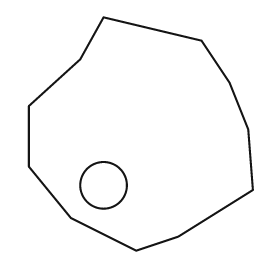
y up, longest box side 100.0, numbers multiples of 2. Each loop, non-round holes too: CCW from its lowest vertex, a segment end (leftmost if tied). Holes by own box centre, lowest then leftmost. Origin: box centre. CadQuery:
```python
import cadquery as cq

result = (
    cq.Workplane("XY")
    .moveTo(-2.0, -50.0)
    .lineTo(16.0, -44.0)
    .lineTo(48.0, -24.0)
    .lineTo(46.0, 2.0)
    .lineTo(38.0, 22.0)
    .lineTo(26.0, 40.0)
    .lineTo(-16.0, 50.0)
    .lineTo(-26.0, 32.0)
    .lineTo(-48.0, 12.0)
    .lineTo(-48.0, -14.0)
    .lineTo(-30.0, -36.0)
    .close()
    .moveTo(-16.0, -22.0)
    .circle(10.0)
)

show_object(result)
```